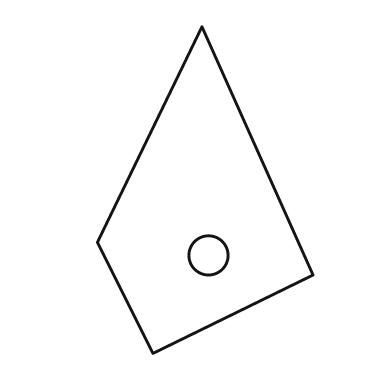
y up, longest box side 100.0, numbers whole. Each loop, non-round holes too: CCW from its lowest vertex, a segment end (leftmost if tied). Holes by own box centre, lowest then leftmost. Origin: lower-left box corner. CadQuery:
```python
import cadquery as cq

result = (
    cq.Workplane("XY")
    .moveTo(17.0, 0.0)
    .lineTo(66.0, 24.0)
    .lineTo(32.0, 100.0)
    .lineTo(0.0, 34.0)
    .close()
    .moveTo(34.0, 30.0)
    .circle(6.0)
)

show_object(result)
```